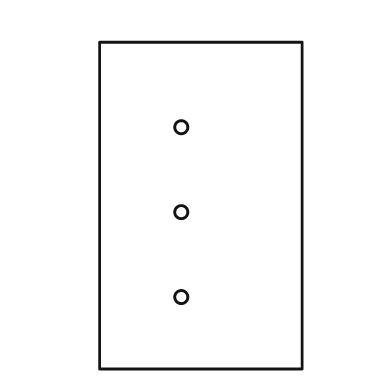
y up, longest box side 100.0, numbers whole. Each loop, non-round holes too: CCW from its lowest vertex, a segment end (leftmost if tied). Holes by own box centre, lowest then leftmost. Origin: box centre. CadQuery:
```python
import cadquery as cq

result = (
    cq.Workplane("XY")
    .moveTo(-31.0, -50.0)
    .lineTo(31.0, -50.0)
    .lineTo(31.0, 50.0)
    .lineTo(-31.0, 50.0)
    .close()
    .moveTo(-6.0, -28.0)
    .circle(2.0)
    .moveTo(-6.0, -2.0)
    .circle(2.0)
    .moveTo(-6.0, 24.0)
    .circle(2.0)
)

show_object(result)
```